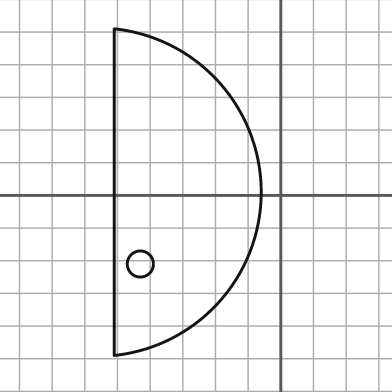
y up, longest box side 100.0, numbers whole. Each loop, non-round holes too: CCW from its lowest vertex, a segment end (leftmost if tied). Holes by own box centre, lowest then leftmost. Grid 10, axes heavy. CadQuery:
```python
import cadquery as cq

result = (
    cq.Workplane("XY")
    .moveTo(-51.0, -49.0)
    .threePointArc((-6.0, 1.0), (-51.0, 51.0))
    .close()
    .moveTo(-43.0, -21.0)
    .circle(4.0)
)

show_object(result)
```